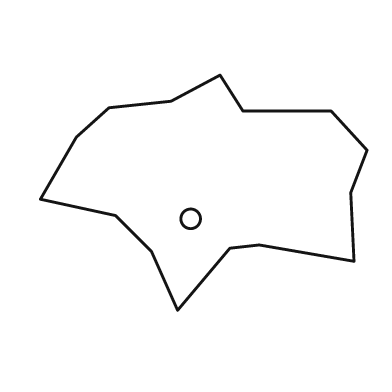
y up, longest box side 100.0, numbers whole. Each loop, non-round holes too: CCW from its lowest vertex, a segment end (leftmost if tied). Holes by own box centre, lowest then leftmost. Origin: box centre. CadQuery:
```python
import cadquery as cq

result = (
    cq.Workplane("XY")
    .moveTo(-8.0, -36.0)
    .lineTo(8.0, -17.0)
    .lineTo(17.0, -16.0)
    .lineTo(46.0, -21.0)
    .lineTo(45.0, 0.0)
    .lineTo(50.0, 13.0)
    .lineTo(39.0, 25.0)
    .lineTo(12.0, 25.0)
    .lineTo(5.0, 36.0)
    .lineTo(-10.0, 28.0)
    .lineTo(-29.0, 26.0)
    .lineTo(-39.0, 17.0)
    .lineTo(-50.0, -2.0)
    .lineTo(-27.0, -7.0)
    .lineTo(-16.0, -18.0)
    .close()
    .moveTo(-4.0, -8.0)
    .circle(3.0)
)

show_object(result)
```